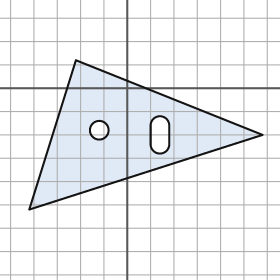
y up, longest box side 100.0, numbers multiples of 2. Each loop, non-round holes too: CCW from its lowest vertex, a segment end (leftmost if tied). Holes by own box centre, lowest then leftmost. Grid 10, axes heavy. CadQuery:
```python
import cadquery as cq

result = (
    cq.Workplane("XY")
    .moveTo(-42.0, -52.0)
    .lineTo(58.0, -20.0)
    .lineTo(-22.0, 12.0)
    .close()
    .moveTo(10.0, -24.0)
    .threePointArc((14.0, -28.0), (18.0, -24.0))
    .lineTo(18.0, -16.0)
    .threePointArc((14.0, -12.0), (10.0, -16.0))
    .close()
    .moveTo(-12.0, -18.0)
    .circle(4.0)
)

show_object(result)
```